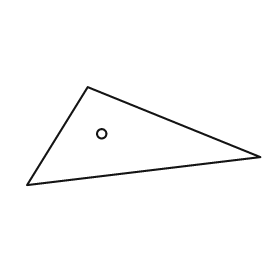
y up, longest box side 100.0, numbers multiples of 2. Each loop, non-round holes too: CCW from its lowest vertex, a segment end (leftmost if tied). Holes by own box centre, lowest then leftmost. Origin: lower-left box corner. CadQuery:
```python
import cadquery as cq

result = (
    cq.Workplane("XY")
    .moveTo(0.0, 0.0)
    .lineTo(100.0, 12.0)
    .lineTo(26.0, 42.0)
    .close()
    .moveTo(32.0, 22.0)
    .circle(2.0)
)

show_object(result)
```